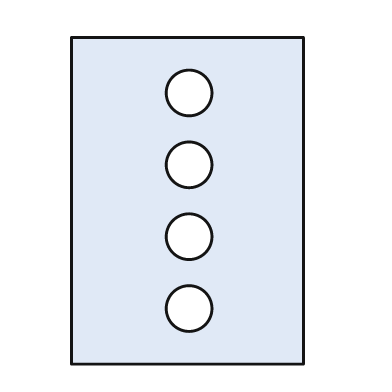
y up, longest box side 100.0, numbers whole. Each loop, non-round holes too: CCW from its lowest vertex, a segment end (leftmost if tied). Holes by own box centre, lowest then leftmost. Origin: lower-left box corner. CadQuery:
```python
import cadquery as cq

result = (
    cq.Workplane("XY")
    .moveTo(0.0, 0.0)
    .lineTo(71.0, 0.0)
    .lineTo(71.0, 100.0)
    .lineTo(0.0, 100.0)
    .close()
    .moveTo(36.0, 17.0)
    .circle(7.0)
    .moveTo(36.0, 39.0)
    .circle(7.0)
    .moveTo(36.0, 61.0)
    .circle(7.0)
    .moveTo(36.0, 83.0)
    .circle(7.0)
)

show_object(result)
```